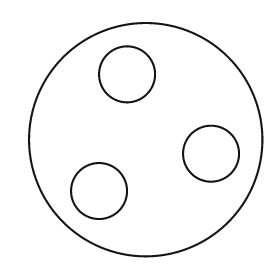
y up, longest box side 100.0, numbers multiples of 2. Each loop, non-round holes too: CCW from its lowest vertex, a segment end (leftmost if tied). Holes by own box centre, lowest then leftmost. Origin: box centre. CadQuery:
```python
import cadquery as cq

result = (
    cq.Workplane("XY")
    .moveTo(0.0, 0.0)
    .circle(50.0)
    .moveTo(-20.0, -22.0)
    .circle(12.0)
    .moveTo(28.0, -6.0)
    .circle(12.0)
    .moveTo(-8.0, 28.0)
    .circle(12.0)
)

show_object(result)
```